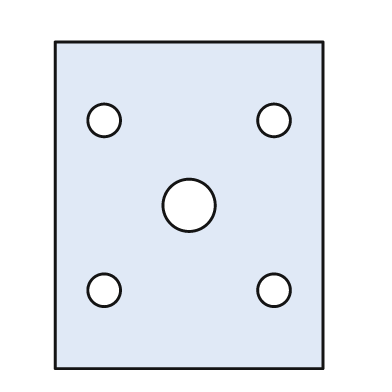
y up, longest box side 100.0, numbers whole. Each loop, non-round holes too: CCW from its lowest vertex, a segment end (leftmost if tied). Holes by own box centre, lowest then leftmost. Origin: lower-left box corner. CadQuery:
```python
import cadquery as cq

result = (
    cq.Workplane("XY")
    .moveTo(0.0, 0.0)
    .lineTo(82.0, 0.0)
    .lineTo(82.0, 100.0)
    .lineTo(0.0, 100.0)
    .close()
    .moveTo(15.0, 24.0)
    .circle(5.0)
    .moveTo(67.0, 24.0)
    .circle(5.0)
    .moveTo(41.0, 50.0)
    .circle(8.0)
    .moveTo(15.0, 76.0)
    .circle(5.0)
    .moveTo(67.0, 76.0)
    .circle(5.0)
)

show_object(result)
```